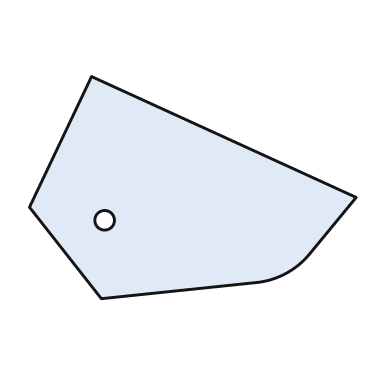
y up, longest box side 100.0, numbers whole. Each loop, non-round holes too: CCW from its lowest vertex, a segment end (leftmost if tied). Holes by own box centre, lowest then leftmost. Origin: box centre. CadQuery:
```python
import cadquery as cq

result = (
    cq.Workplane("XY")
    .moveTo(-28.0, -34.0)
    .lineTo(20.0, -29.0)
    .threePointArc((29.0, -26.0), (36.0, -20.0))
    .lineTo(50.0, -3.0)
    .lineTo(-31.0, 34.0)
    .lineTo(-50.0, -6.0)
    .close()
    .moveTo(-27.0, -10.0)
    .circle(3.0)
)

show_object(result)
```